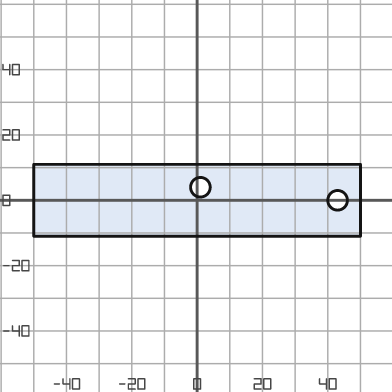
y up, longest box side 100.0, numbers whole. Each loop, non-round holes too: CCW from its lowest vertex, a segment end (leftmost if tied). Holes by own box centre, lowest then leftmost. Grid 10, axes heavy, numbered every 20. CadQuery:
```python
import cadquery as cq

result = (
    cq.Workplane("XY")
    .moveTo(-50.0, -11.0)
    .lineTo(50.0, -11.0)
    .lineTo(50.0, 11.0)
    .lineTo(-50.0, 11.0)
    .close()
    .moveTo(43.0, 0.0)
    .circle(3.0)
    .moveTo(1.0, 4.0)
    .circle(3.0)
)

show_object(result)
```